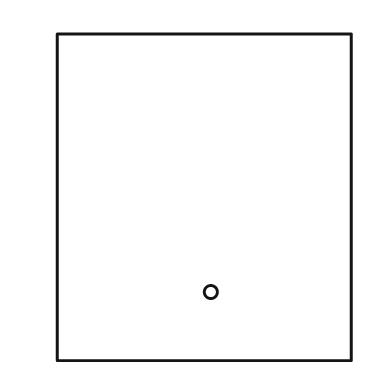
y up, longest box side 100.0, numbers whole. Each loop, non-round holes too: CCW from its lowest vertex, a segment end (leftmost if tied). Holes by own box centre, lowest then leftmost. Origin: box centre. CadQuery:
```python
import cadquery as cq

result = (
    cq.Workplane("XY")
    .moveTo(-45.0, -50.0)
    .lineTo(45.0, -50.0)
    .lineTo(45.0, 50.0)
    .lineTo(-45.0, 50.0)
    .close()
    .moveTo(2.0, -29.0)
    .circle(2.0)
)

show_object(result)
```